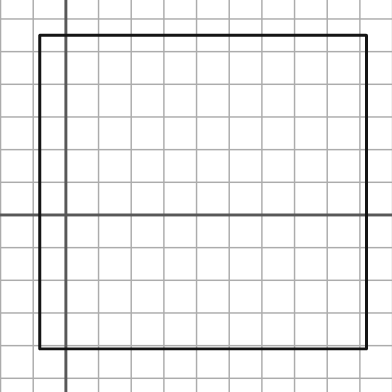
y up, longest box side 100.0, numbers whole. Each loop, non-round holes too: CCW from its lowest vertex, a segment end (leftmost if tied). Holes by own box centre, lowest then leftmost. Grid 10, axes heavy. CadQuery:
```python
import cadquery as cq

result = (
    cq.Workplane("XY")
    .moveTo(-8.0, -41.0)
    .lineTo(92.0, -41.0)
    .lineTo(92.0, 55.0)
    .lineTo(-8.0, 55.0)
    .close()
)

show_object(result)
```